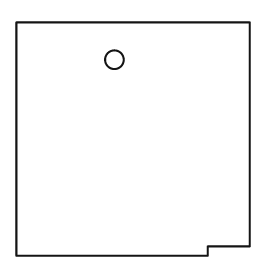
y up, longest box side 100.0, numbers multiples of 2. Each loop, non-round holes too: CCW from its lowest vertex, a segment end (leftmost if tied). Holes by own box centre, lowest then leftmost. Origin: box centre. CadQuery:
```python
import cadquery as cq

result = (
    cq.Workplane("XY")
    .moveTo(-50.0, -50.0)
    .lineTo(32.0, -50.0)
    .lineTo(32.0, -46.0)
    .lineTo(50.0, -46.0)
    .lineTo(50.0, 50.0)
    .lineTo(-50.0, 50.0)
    .close()
    .moveTo(-8.0, 34.0)
    .circle(4.0)
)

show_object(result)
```